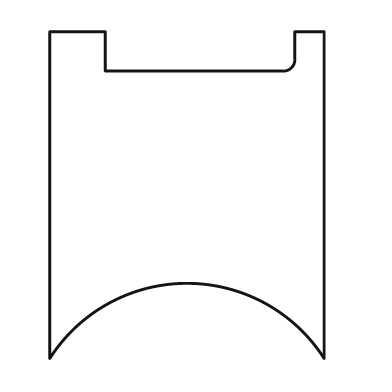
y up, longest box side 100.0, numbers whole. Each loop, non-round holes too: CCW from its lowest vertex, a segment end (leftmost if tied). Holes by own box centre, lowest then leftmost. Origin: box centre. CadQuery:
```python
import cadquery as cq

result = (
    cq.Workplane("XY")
    .moveTo(-42.0, -50.0)
    .threePointArc((0.0, -27.0), (42.0, -50.0))
    .lineTo(42.0, 50.0)
    .lineTo(33.0, 50.0)
    .lineTo(33.0, 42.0)
    .threePointArc((32.0, 39.0), (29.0, 38.0))
    .lineTo(-25.0, 38.0)
    .lineTo(-25.0, 50.0)
    .lineTo(-42.0, 50.0)
    .close()
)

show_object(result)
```